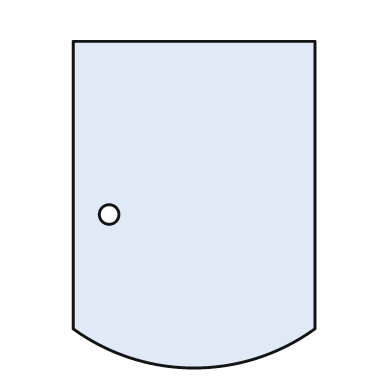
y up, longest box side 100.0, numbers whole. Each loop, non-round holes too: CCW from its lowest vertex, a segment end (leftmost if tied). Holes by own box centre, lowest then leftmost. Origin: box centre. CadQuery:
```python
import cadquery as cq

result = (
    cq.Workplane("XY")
    .moveTo(-37.0, -38.0)
    .threePointArc((0.0, -50.0), (37.0, -38.0))
    .lineTo(37.0, 50.0)
    .lineTo(-37.0, 50.0)
    .close()
    .moveTo(-26.0, -3.0)
    .circle(3.0)
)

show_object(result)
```